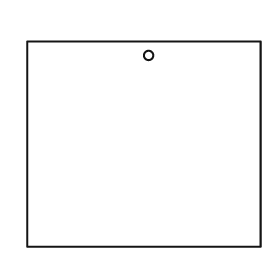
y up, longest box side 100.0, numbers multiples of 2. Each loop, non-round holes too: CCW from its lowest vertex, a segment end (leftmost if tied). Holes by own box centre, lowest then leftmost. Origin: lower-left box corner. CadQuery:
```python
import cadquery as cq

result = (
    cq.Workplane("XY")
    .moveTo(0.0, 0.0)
    .lineTo(100.0, 0.0)
    .lineTo(100.0, 88.0)
    .lineTo(0.0, 88.0)
    .close()
    .moveTo(52.0, 82.0)
    .circle(2.0)
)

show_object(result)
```